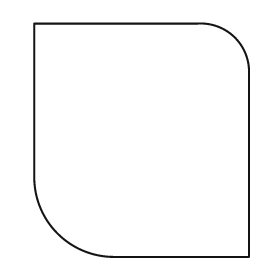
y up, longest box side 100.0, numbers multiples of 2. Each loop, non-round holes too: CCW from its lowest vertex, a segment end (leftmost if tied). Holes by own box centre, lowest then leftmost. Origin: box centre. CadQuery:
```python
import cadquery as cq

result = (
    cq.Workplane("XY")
    .moveTo(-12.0, -50.0)
    .lineTo(46.0, -50.0)
    .lineTo(46.0, 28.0)
    .threePointArc((40.0, 44.0), (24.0, 50.0))
    .lineTo(-46.0, 50.0)
    .lineTo(-46.0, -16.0)
    .threePointArc((-36.0, -40.0), (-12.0, -50.0))
    .close()
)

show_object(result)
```